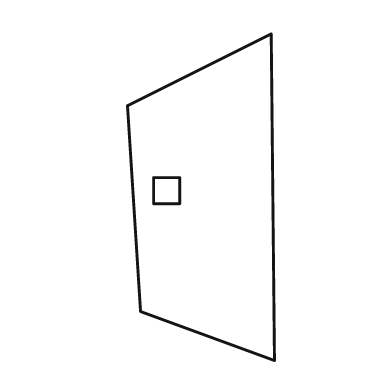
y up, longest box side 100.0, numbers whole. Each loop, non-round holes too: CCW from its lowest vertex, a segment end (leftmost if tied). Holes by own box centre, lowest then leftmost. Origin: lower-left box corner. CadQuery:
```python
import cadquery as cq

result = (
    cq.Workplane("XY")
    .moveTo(45.0, 0.0)
    .lineTo(44.0, 100.0)
    .lineTo(0.0, 78.0)
    .lineTo(4.0, 15.0)
    .close()
    .moveTo(8.0, 48.0)
    .lineTo(16.0, 48.0)
    .lineTo(16.0, 56.0)
    .lineTo(8.0, 56.0)
    .close()
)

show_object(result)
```